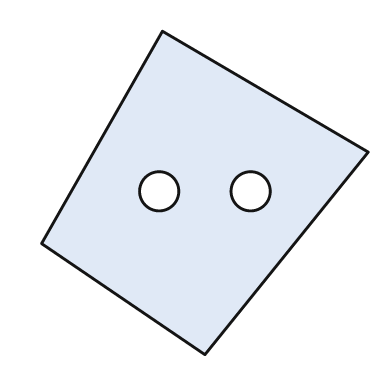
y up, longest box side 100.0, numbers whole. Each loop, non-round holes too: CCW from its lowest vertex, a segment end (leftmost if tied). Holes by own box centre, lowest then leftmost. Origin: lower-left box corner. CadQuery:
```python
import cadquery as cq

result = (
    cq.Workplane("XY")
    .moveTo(50.0, 0.0)
    .lineTo(100.0, 62.0)
    .lineTo(37.0, 99.0)
    .lineTo(0.0, 34.0)
    .close()
    .moveTo(36.0, 50.0)
    .circle(6.0)
    .moveTo(64.0, 50.0)
    .circle(6.0)
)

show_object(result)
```